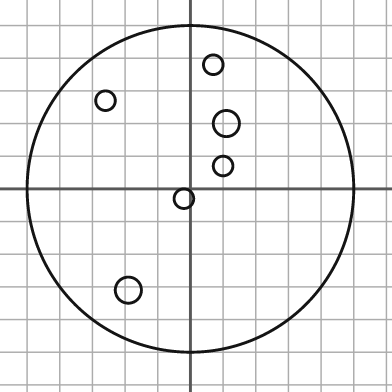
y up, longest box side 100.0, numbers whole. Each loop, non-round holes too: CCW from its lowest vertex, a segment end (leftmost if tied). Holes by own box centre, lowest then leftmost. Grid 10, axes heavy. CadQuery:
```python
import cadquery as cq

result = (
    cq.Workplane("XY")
    .moveTo(0.0, 0.0)
    .circle(50.0)
    .moveTo(-19.0, -31.0)
    .circle(4.0)
    .moveTo(-2.0, -3.0)
    .circle(3.0)
    .moveTo(10.0, 7.0)
    .circle(3.0)
    .moveTo(11.0, 20.0)
    .circle(4.0)
    .moveTo(-26.0, 27.0)
    .circle(3.0)
    .moveTo(7.0, 38.0)
    .circle(3.0)
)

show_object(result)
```